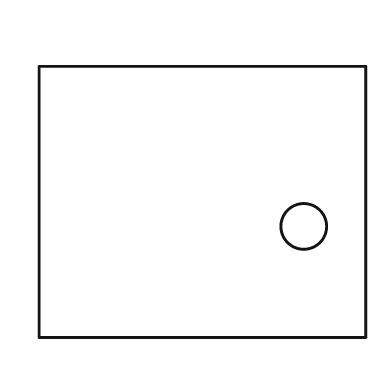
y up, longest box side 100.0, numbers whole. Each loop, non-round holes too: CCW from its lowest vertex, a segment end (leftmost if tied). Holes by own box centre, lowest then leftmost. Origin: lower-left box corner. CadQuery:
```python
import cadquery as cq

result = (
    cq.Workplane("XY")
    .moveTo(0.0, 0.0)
    .lineTo(100.0, 0.0)
    .lineTo(100.0, 83.0)
    .lineTo(0.0, 83.0)
    .close()
    .moveTo(81.0, 34.0)
    .circle(7.0)
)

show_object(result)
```